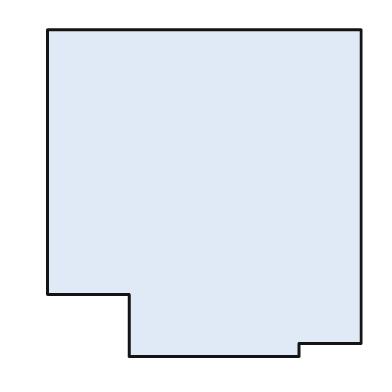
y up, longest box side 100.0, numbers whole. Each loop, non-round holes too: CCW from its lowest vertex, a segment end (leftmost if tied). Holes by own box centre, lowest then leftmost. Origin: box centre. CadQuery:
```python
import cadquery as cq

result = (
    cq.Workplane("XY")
    .moveTo(-23.0, -50.0)
    .lineTo(29.0, -50.0)
    .lineTo(29.0, -46.0)
    .lineTo(48.0, -46.0)
    .lineTo(48.0, 50.0)
    .lineTo(-48.0, 50.0)
    .lineTo(-48.0, -31.0)
    .lineTo(-23.0, -31.0)
    .close()
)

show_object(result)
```